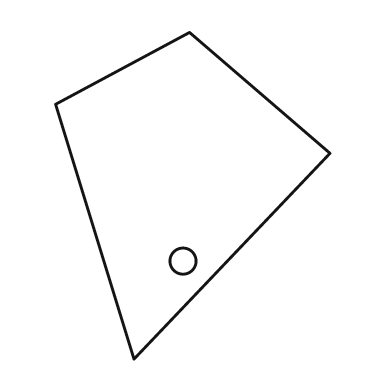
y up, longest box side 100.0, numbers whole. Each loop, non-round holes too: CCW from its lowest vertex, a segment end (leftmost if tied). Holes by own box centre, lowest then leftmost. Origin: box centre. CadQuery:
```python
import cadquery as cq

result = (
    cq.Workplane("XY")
    .moveTo(-18.0, -50.0)
    .lineTo(42.0, 13.0)
    .lineTo(-1.0, 50.0)
    .lineTo(-42.0, 28.0)
    .close()
    .moveTo(-3.0, -20.0)
    .circle(4.0)
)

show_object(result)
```